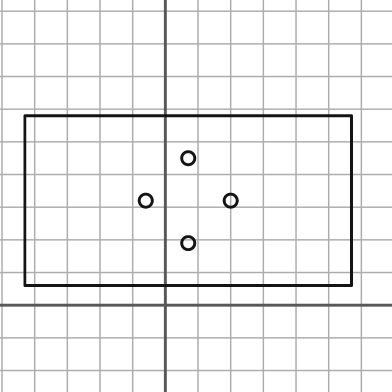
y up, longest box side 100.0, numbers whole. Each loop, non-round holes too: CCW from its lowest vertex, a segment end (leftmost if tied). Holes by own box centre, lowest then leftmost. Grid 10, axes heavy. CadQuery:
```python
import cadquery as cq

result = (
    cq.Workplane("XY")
    .moveTo(-43.0, 6.0)
    .lineTo(57.0, 6.0)
    .lineTo(57.0, 58.0)
    .lineTo(-43.0, 58.0)
    .close()
    .moveTo(7.0, 19.0)
    .circle(2.0)
    .moveTo(-6.0, 32.0)
    .circle(2.0)
    .moveTo(20.0, 32.0)
    .circle(2.0)
    .moveTo(7.0, 45.0)
    .circle(2.0)
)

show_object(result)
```